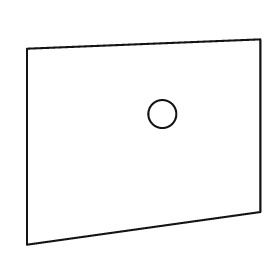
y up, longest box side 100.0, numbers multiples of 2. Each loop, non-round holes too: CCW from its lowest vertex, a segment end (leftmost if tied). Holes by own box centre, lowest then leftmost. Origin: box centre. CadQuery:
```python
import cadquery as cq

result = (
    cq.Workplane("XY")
    .moveTo(-50.0, -44.0)
    .lineTo(50.0, -30.0)
    .lineTo(50.0, 44.0)
    .lineTo(-50.0, 40.0)
    .close()
    .moveTo(8.0, 12.0)
    .circle(6.0)
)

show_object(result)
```